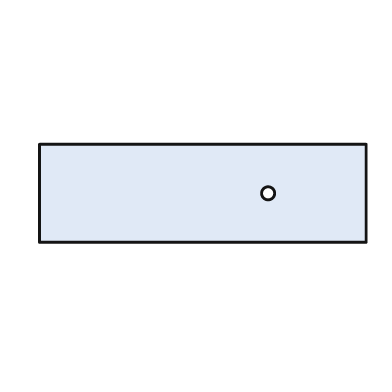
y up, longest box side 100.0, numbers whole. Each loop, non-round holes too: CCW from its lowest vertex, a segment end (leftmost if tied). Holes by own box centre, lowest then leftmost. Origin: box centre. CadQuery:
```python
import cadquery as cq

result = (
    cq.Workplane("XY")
    .moveTo(-50.0, -15.0)
    .lineTo(50.0, -15.0)
    .lineTo(50.0, 15.0)
    .lineTo(-50.0, 15.0)
    .close()
    .moveTo(20.0, 0.0)
    .circle(2.0)
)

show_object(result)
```